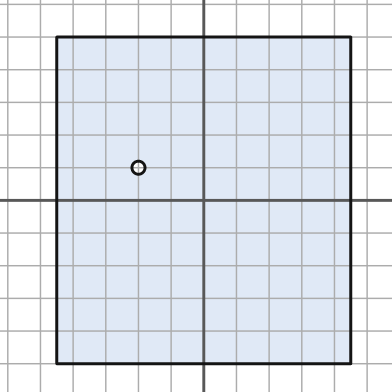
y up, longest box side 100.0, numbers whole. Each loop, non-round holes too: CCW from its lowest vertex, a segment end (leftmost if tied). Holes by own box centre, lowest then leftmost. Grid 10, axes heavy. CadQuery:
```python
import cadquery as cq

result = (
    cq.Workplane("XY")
    .moveTo(-45.0, -50.0)
    .lineTo(45.0, -50.0)
    .lineTo(45.0, 50.0)
    .lineTo(-45.0, 50.0)
    .close()
    .moveTo(-20.0, 10.0)
    .circle(2.0)
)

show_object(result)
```